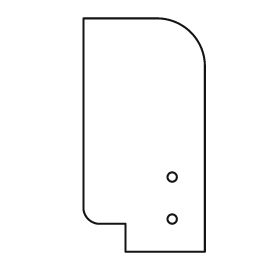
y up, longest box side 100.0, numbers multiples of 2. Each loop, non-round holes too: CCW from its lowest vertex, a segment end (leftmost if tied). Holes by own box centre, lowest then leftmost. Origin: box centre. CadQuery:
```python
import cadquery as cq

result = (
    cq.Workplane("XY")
    .moveTo(-8.0, -50.0)
    .lineTo(26.0, -50.0)
    .lineTo(26.0, 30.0)
    .threePointArc((20.0, 44.0), (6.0, 50.0))
    .lineTo(-26.0, 50.0)
    .lineTo(-26.0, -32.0)
    .threePointArc((-24.0, -36.0), (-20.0, -38.0))
    .lineTo(-8.0, -38.0)
    .close()
    .moveTo(12.0, -36.0)
    .circle(2.0)
    .moveTo(12.0, -18.0)
    .circle(2.0)
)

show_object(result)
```